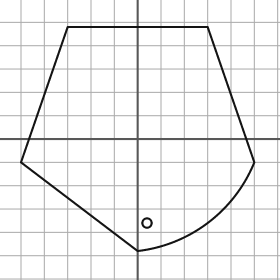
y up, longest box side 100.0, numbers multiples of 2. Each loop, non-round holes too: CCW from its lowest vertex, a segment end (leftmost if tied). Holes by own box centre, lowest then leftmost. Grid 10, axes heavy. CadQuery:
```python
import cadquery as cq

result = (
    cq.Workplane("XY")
    .moveTo(0.0, -48.0)
    .threePointArc((30.0, -36.0), (50.0, -10.0))
    .lineTo(30.0, 48.0)
    .lineTo(-30.0, 48.0)
    .lineTo(-50.0, -10.0)
    .close()
    .moveTo(4.0, -36.0)
    .circle(2.0)
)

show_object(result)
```